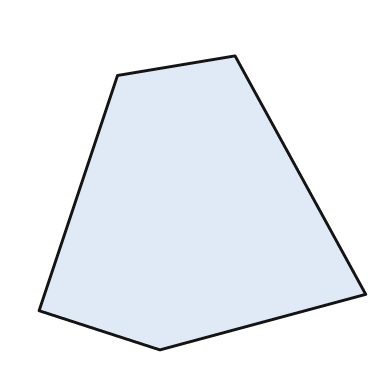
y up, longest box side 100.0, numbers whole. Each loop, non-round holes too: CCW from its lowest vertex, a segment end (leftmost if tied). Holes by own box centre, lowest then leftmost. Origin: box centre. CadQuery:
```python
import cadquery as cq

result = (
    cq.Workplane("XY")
    .moveTo(-13.0, -45.0)
    .lineTo(50.0, -28.0)
    .lineTo(10.0, 45.0)
    .lineTo(-26.0, 39.0)
    .lineTo(-50.0, -33.0)
    .close()
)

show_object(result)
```